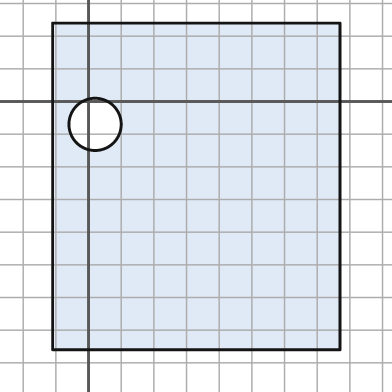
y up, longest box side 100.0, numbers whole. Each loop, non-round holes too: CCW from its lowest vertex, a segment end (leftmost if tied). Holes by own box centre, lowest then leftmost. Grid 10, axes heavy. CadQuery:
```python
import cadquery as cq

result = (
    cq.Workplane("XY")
    .moveTo(-11.0, -76.0)
    .lineTo(77.0, -76.0)
    .lineTo(77.0, 24.0)
    .lineTo(-11.0, 24.0)
    .close()
    .moveTo(2.0, -7.0)
    .circle(8.0)
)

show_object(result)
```